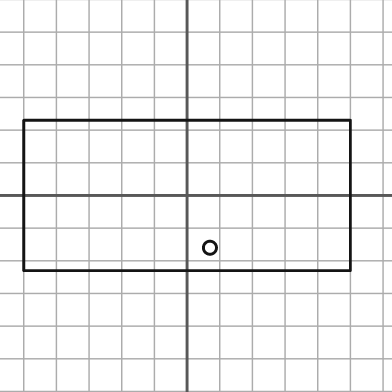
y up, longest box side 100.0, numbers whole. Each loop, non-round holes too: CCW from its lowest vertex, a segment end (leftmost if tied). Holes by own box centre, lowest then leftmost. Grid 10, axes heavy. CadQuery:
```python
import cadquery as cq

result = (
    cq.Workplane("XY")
    .moveTo(-50.0, -23.0)
    .lineTo(50.0, -23.0)
    .lineTo(50.0, 23.0)
    .lineTo(-50.0, 23.0)
    .close()
    .moveTo(7.0, -16.0)
    .circle(2.0)
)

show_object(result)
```